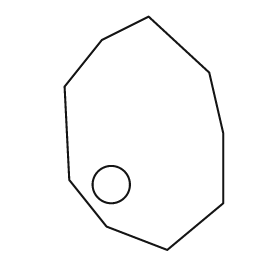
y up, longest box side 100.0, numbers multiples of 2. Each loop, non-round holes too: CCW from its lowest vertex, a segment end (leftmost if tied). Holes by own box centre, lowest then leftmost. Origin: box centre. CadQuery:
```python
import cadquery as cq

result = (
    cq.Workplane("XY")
    .moveTo(10.0, -50.0)
    .lineTo(34.0, -30.0)
    .lineTo(34.0, 0.0)
    .lineTo(28.0, 26.0)
    .lineTo(2.0, 50.0)
    .lineTo(-18.0, 40.0)
    .lineTo(-34.0, 20.0)
    .lineTo(-32.0, -20.0)
    .lineTo(-16.0, -40.0)
    .close()
    .moveTo(-14.0, -22.0)
    .circle(8.0)
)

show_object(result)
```